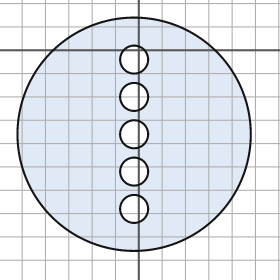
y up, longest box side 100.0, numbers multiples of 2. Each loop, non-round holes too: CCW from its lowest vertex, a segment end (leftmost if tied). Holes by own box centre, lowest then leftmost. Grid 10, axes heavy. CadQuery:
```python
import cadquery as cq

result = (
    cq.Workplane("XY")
    .moveTo(-2.0, -36.0)
    .circle(50.0)
    .moveTo(-2.0, -68.0)
    .circle(6.0)
    .moveTo(-2.0, -52.0)
    .circle(6.0)
    .moveTo(-2.0, -36.0)
    .circle(6.0)
    .moveTo(-2.0, -20.0)
    .circle(6.0)
    .moveTo(-2.0, -4.0)
    .circle(6.0)
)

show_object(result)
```